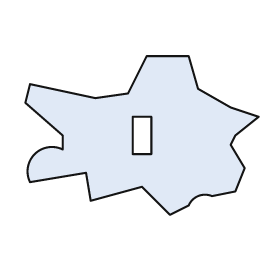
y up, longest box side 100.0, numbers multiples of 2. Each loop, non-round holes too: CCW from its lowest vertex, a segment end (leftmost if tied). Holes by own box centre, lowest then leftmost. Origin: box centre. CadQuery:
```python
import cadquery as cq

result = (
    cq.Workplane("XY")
    .moveTo(12.0, -34.0)
    .lineTo(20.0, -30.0)
    .threePointArc((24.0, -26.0), (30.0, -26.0))
    .lineTo(40.0, -24.0)
    .lineTo(44.0, -14.0)
    .lineTo(38.0, -4.0)
    .lineTo(40.0, 0.0)
    .lineTo(50.0, 8.0)
    .lineTo(38.0, 12.0)
    .lineTo(24.0, 20.0)
    .lineTo(20.0, 34.0)
    .lineTo(2.0, 34.0)
    .lineTo(-6.0, 18.0)
    .lineTo(-20.0, 16.0)
    .lineTo(-48.0, 22.0)
    .lineTo(-50.0, 14.0)
    .lineTo(-34.0, 0.0)
    .lineTo(-34.0, -6.0)
    .threePointArc((-46.0, -8.0), (-48.0, -20.0))
    .lineTo(-24.0, -16.0)
    .lineTo(-22.0, -28.0)
    .lineTo(0.0, -22.0)
    .close()
    .moveTo(-4.0, -8.0)
    .lineTo(4.0, -8.0)
    .lineTo(4.0, 8.0)
    .lineTo(-4.0, 8.0)
    .close()
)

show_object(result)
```